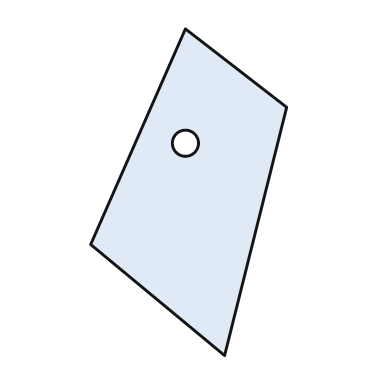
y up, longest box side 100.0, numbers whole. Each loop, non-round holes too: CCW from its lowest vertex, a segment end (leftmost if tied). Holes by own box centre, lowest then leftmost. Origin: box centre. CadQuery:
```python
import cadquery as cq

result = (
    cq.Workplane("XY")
    .moveTo(11.0, -50.0)
    .lineTo(30.0, 26.0)
    .lineTo(-1.0, 50.0)
    .lineTo(-30.0, -16.0)
    .close()
    .moveTo(-1.0, 15.0)
    .circle(4.0)
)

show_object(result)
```